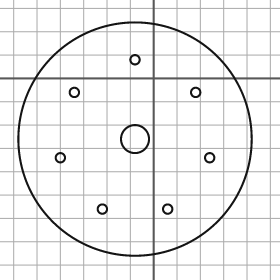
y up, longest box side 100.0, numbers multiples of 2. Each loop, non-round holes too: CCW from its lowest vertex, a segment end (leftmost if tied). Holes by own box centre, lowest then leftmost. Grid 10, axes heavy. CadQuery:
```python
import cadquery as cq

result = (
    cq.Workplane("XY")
    .moveTo(-8.0, -26.0)
    .circle(50.0)
    .moveTo(-22.0, -56.0)
    .circle(2.0)
    .moveTo(6.0, -56.0)
    .circle(2.0)
    .moveTo(-40.0, -34.0)
    .circle(2.0)
    .moveTo(24.0, -34.0)
    .circle(2.0)
    .moveTo(-8.0, -26.0)
    .circle(6.0)
    .moveTo(-34.0, -6.0)
    .circle(2.0)
    .moveTo(18.0, -6.0)
    .circle(2.0)
    .moveTo(-8.0, 8.0)
    .circle(2.0)
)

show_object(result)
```